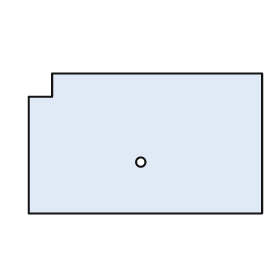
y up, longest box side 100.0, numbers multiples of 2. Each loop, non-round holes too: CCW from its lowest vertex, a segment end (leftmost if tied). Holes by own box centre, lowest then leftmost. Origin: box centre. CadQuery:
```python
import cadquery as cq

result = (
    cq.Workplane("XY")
    .moveTo(-50.0, -30.0)
    .lineTo(50.0, -30.0)
    .lineTo(50.0, 30.0)
    .lineTo(-40.0, 30.0)
    .lineTo(-40.0, 20.0)
    .lineTo(-50.0, 20.0)
    .close()
    .moveTo(-2.0, -8.0)
    .circle(2.0)
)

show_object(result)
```